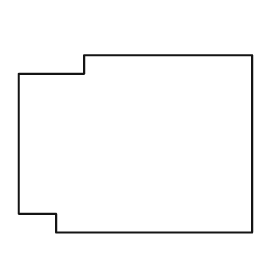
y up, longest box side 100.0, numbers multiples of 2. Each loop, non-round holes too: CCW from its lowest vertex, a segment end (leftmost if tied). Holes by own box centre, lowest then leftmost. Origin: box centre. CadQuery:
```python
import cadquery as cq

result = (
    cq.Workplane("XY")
    .moveTo(-34.0, -38.0)
    .lineTo(50.0, -38.0)
    .lineTo(50.0, 38.0)
    .lineTo(-22.0, 38.0)
    .lineTo(-22.0, 30.0)
    .lineTo(-50.0, 30.0)
    .lineTo(-50.0, -30.0)
    .lineTo(-34.0, -30.0)
    .close()
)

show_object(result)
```